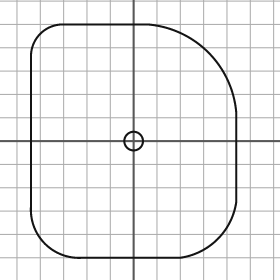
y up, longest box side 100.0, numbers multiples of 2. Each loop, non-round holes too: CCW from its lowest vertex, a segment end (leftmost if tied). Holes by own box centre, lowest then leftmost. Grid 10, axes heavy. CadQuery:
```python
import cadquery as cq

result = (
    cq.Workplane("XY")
    .moveTo(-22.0, -50.0)
    .lineTo(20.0, -50.0)
    .threePointArc((36.0, -42.0), (44.0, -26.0))
    .lineTo(44.0, 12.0)
    .threePointArc((32.0, 38.0), (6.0, 50.0))
    .lineTo(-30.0, 50.0)
    .threePointArc((-40.0, 46.0), (-44.0, 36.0))
    .lineTo(-44.0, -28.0)
    .threePointArc((-38.0, -44.0), (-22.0, -50.0))
    .close()
    .moveTo(0.0, 0.0)
    .circle(4.0)
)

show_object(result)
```